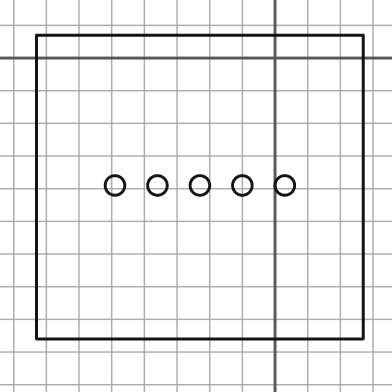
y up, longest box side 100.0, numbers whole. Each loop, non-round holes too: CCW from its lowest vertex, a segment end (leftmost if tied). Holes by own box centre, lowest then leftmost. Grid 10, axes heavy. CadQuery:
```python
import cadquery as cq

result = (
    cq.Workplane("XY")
    .moveTo(-73.0, -86.0)
    .lineTo(27.0, -86.0)
    .lineTo(27.0, 7.0)
    .lineTo(-73.0, 7.0)
    .close()
    .moveTo(-49.0, -39.0)
    .circle(3.0)
    .moveTo(-36.0, -39.0)
    .circle(3.0)
    .moveTo(-23.0, -39.0)
    .circle(3.0)
    .moveTo(-10.0, -39.0)
    .circle(3.0)
    .moveTo(3.0, -39.0)
    .circle(3.0)
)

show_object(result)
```